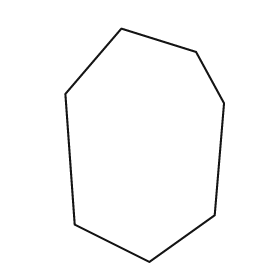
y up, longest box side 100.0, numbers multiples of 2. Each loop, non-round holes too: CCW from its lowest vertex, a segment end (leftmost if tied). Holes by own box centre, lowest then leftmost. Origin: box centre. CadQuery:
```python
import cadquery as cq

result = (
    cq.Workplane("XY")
    .moveTo(2.0, -50.0)
    .lineTo(30.0, -30.0)
    .lineTo(34.0, 18.0)
    .lineTo(22.0, 40.0)
    .lineTo(-10.0, 50.0)
    .lineTo(-34.0, 22.0)
    .lineTo(-30.0, -34.0)
    .close()
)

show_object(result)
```